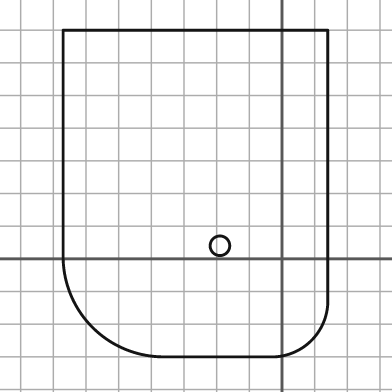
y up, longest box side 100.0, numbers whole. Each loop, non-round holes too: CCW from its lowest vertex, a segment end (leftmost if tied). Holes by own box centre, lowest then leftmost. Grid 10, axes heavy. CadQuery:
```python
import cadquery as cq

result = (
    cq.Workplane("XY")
    .moveTo(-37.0, -30.0)
    .lineTo(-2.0, -30.0)
    .threePointArc((9.0, -25.0), (14.0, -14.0))
    .lineTo(14.0, 70.0)
    .lineTo(-67.0, 70.0)
    .lineTo(-67.0, 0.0)
    .threePointArc((-58.0, -21.0), (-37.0, -30.0))
    .close()
    .moveTo(-19.0, 4.0)
    .circle(3.0)
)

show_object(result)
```